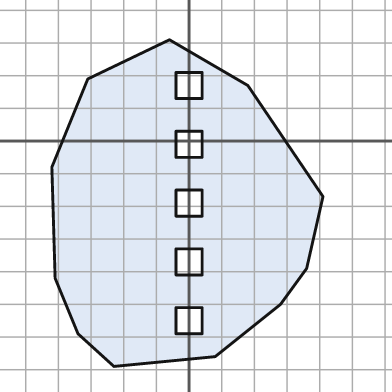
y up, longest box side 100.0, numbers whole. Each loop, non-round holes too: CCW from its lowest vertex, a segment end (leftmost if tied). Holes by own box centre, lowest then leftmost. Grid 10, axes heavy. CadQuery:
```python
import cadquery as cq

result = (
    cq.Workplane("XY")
    .moveTo(-23.0, -69.0)
    .lineTo(8.0, -66.0)
    .lineTo(28.0, -50.0)
    .lineTo(36.0, -39.0)
    .lineTo(41.0, -17.0)
    .lineTo(18.0, 17.0)
    .lineTo(-6.0, 31.0)
    .lineTo(-31.0, 19.0)
    .lineTo(-42.0, -8.0)
    .lineTo(-41.0, -42.0)
    .lineTo(-34.0, -59.0)
    .close()
    .moveTo(-4.0, -59.0)
    .lineTo(4.0, -59.0)
    .lineTo(4.0, -51.0)
    .lineTo(-4.0, -51.0)
    .close()
    .moveTo(-4.0, -41.0)
    .lineTo(4.0, -41.0)
    .lineTo(4.0, -33.0)
    .lineTo(-4.0, -33.0)
    .close()
    .moveTo(-4.0, -23.0)
    .lineTo(4.0, -23.0)
    .lineTo(4.0, -15.0)
    .lineTo(-4.0, -15.0)
    .close()
    .moveTo(-4.0, -5.0)
    .lineTo(4.0, -5.0)
    .lineTo(4.0, 3.0)
    .lineTo(-4.0, 3.0)
    .close()
    .moveTo(-4.0, 13.0)
    .lineTo(4.0, 13.0)
    .lineTo(4.0, 21.0)
    .lineTo(-4.0, 21.0)
    .close()
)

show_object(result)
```